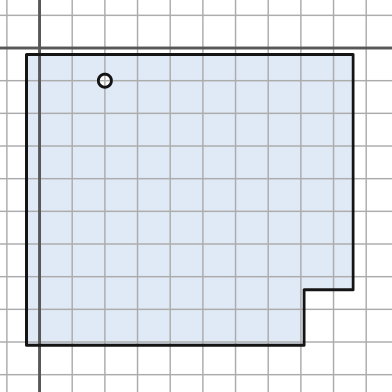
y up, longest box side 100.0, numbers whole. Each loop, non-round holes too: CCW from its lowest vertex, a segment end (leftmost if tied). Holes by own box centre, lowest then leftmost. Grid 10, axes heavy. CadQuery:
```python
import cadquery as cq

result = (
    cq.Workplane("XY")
    .moveTo(-4.0, -91.0)
    .lineTo(81.0, -91.0)
    .lineTo(81.0, -74.0)
    .lineTo(96.0, -74.0)
    .lineTo(96.0, -2.0)
    .lineTo(-4.0, -2.0)
    .close()
    .moveTo(20.0, -10.0)
    .circle(2.0)
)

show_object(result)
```